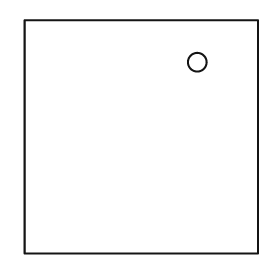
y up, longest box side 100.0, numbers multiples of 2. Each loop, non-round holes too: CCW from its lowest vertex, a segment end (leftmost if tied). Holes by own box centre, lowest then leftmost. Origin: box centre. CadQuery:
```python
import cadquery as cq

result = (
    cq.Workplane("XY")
    .moveTo(-50.0, -50.0)
    .lineTo(50.0, -50.0)
    .lineTo(50.0, 50.0)
    .lineTo(-50.0, 50.0)
    .close()
    .moveTo(24.0, 32.0)
    .circle(4.0)
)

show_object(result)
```